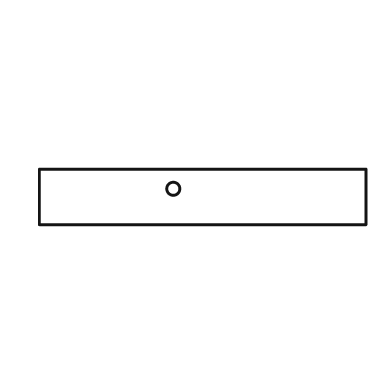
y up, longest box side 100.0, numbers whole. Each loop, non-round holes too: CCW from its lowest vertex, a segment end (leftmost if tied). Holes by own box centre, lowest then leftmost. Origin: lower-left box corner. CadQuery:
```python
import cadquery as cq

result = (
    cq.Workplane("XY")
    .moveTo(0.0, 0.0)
    .lineTo(100.0, 0.0)
    .lineTo(100.0, 17.0)
    .lineTo(0.0, 17.0)
    .close()
    .moveTo(41.0, 11.0)
    .circle(2.0)
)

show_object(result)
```